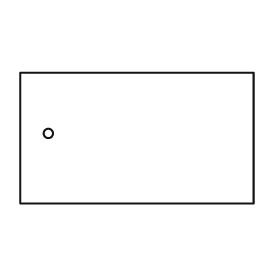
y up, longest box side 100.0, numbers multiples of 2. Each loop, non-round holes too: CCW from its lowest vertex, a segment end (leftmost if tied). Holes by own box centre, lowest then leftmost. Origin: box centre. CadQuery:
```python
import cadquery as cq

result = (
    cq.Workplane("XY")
    .moveTo(-50.0, -28.0)
    .lineTo(50.0, -28.0)
    .lineTo(50.0, 28.0)
    .lineTo(-50.0, 28.0)
    .close()
    .moveTo(-38.0, 2.0)
    .circle(2.0)
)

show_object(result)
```